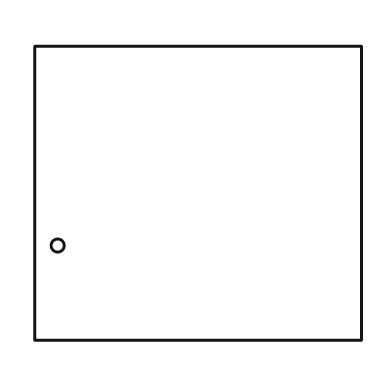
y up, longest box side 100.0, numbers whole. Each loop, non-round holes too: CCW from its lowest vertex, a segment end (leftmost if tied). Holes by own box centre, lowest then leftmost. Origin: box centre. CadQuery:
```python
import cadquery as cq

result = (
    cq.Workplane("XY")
    .moveTo(-50.0, -45.0)
    .lineTo(50.0, -45.0)
    .lineTo(50.0, 45.0)
    .lineTo(-50.0, 45.0)
    .close()
    .moveTo(-43.0, -16.0)
    .circle(2.0)
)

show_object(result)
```